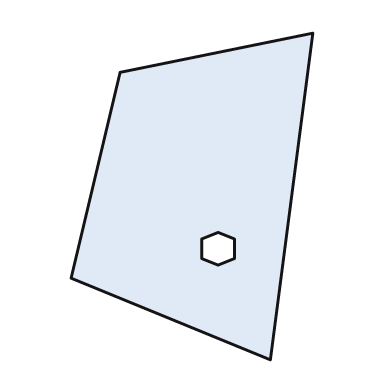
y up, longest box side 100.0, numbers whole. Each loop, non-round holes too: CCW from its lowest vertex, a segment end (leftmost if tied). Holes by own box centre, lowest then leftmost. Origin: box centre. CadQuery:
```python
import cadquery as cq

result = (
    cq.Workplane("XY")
    .moveTo(24.0, -50.0)
    .lineTo(37.0, 50.0)
    .lineTo(-22.0, 38.0)
    .lineTo(-37.0, -25.0)
    .close()
    .moveTo(8.0, -21.0)
    .lineTo(13.0, -19.0)
    .lineTo(13.0, -13.0)
    .lineTo(8.0, -11.0)
    .lineTo(3.0, -13.0)
    .lineTo(3.0, -19.0)
    .close()
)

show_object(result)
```